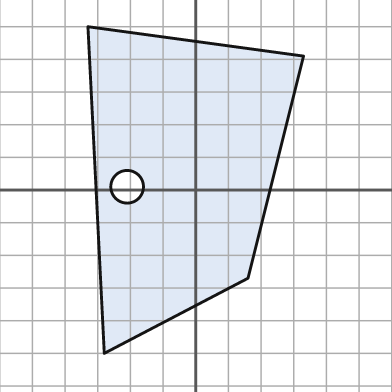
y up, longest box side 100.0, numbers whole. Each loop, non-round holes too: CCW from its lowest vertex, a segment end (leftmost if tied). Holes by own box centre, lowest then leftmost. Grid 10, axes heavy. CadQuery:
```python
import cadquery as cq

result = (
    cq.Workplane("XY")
    .moveTo(-28.0, -50.0)
    .lineTo(16.0, -27.0)
    .lineTo(33.0, 41.0)
    .lineTo(-33.0, 50.0)
    .close()
    .moveTo(-21.0, 1.0)
    .circle(5.0)
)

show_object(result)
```